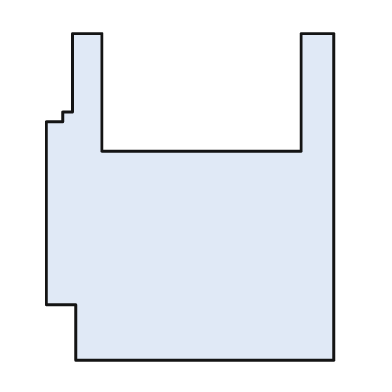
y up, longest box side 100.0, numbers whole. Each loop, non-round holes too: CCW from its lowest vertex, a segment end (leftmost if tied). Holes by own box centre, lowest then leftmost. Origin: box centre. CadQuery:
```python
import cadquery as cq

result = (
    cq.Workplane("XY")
    .moveTo(-35.0, -50.0)
    .lineTo(44.0, -50.0)
    .lineTo(44.0, 50.0)
    .lineTo(34.0, 50.0)
    .lineTo(34.0, 14.0)
    .lineTo(-27.0, 14.0)
    .lineTo(-27.0, 50.0)
    .lineTo(-36.0, 50.0)
    .lineTo(-36.0, 26.0)
    .lineTo(-39.0, 26.0)
    .lineTo(-39.0, 23.0)
    .lineTo(-44.0, 23.0)
    .lineTo(-44.0, -33.0)
    .lineTo(-35.0, -33.0)
    .close()
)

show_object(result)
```